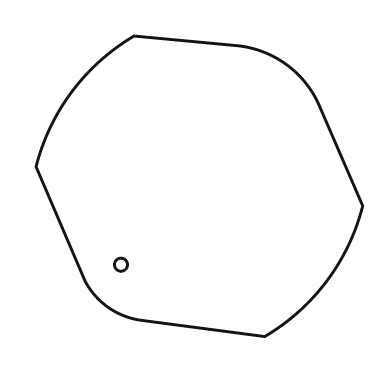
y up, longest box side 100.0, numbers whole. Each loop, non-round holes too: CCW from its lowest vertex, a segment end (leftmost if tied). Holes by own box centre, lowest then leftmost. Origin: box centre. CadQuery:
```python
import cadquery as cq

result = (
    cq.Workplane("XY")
    .moveTo(20.0, -46.0)
    .threePointArc((39.0, -29.0), (50.0, -6.0))
    .lineTo(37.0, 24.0)
    .threePointArc((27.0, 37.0), (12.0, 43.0))
    .lineTo(-20.0, 46.0)
    .threePointArc((-39.0, 29.0), (-50.0, 6.0))
    .lineTo(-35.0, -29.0)
    .threePointArc((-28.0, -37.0), (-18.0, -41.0))
    .close()
    .moveTo(-24.0, -24.0)
    .circle(2.0)
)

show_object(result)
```